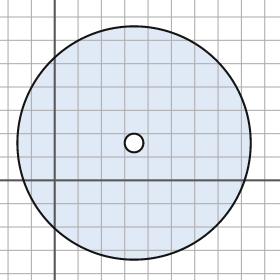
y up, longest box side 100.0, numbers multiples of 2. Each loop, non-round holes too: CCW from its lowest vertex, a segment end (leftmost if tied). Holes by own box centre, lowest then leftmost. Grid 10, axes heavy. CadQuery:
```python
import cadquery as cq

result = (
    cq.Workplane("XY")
    .moveTo(34.0, 16.0)
    .circle(50.0)
    .moveTo(34.0, 16.0)
    .circle(4.0)
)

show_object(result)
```